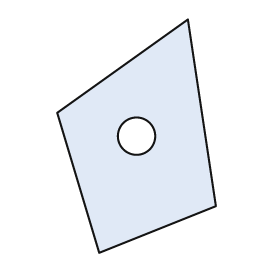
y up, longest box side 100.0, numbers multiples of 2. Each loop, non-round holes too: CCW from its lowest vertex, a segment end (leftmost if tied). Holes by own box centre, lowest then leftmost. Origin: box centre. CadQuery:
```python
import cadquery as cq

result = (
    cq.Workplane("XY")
    .moveTo(-16.0, -50.0)
    .lineTo(34.0, -30.0)
    .lineTo(22.0, 50.0)
    .lineTo(-34.0, 10.0)
    .close()
    .moveTo(0.0, 0.0)
    .circle(8.0)
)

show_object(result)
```